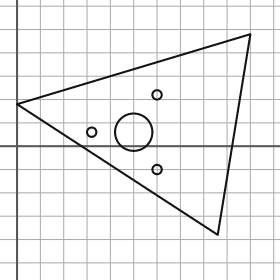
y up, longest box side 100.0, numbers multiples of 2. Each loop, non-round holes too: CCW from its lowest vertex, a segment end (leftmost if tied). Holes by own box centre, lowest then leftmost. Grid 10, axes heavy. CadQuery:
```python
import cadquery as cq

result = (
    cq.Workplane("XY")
    .moveTo(86.0, -38.0)
    .lineTo(100.0, 48.0)
    .lineTo(0.0, 18.0)
    .close()
    .moveTo(60.0, -10.0)
    .circle(2.0)
    .moveTo(32.0, 6.0)
    .circle(2.0)
    .moveTo(50.0, 6.0)
    .circle(8.0)
    .moveTo(60.0, 22.0)
    .circle(2.0)
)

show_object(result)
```